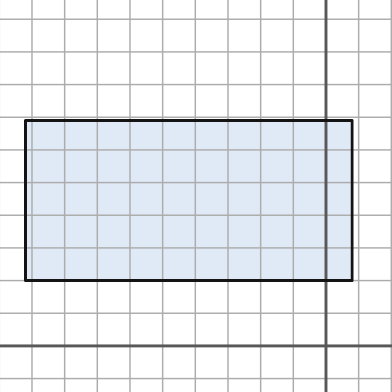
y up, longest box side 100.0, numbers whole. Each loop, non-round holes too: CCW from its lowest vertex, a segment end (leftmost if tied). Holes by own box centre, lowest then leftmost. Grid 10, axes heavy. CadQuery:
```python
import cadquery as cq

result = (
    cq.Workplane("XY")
    .moveTo(-92.0, 20.0)
    .lineTo(8.0, 20.0)
    .lineTo(8.0, 69.0)
    .lineTo(-92.0, 69.0)
    .close()
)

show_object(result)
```